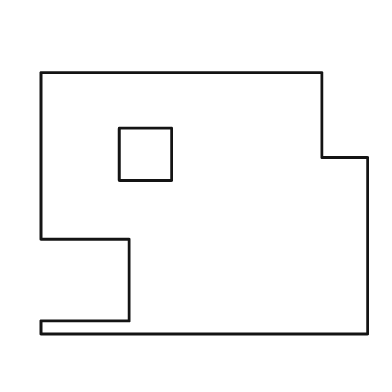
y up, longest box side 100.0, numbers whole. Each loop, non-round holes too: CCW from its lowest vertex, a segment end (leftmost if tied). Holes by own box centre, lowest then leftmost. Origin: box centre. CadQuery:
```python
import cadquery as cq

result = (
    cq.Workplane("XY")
    .moveTo(-50.0, -40.0)
    .lineTo(50.0, -40.0)
    .lineTo(50.0, 14.0)
    .lineTo(36.0, 14.0)
    .lineTo(36.0, 40.0)
    .lineTo(-50.0, 40.0)
    .lineTo(-50.0, -11.0)
    .lineTo(-23.0, -11.0)
    .lineTo(-23.0, -36.0)
    .lineTo(-50.0, -36.0)
    .close()
    .moveTo(-26.0, 7.0)
    .lineTo(-10.0, 7.0)
    .lineTo(-10.0, 23.0)
    .lineTo(-26.0, 23.0)
    .close()
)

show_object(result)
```